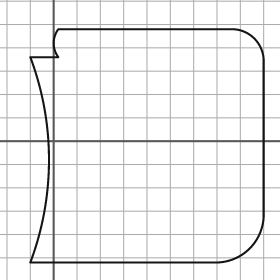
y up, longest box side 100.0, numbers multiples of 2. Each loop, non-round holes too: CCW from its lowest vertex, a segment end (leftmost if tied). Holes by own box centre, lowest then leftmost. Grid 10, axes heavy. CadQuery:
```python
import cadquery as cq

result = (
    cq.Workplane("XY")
    .moveTo(-10.0, -52.0)
    .lineTo(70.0, -52.0)
    .threePointArc((84.0, -46.0), (90.0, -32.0))
    .lineTo(90.0, 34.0)
    .threePointArc((86.0, 44.0), (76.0, 48.0))
    .lineTo(2.0, 48.0)
    .threePointArc((0.0, 42.0), (2.0, 36.0))
    .lineTo(-10.0, 36.0)
    .threePointArc((-2.0, -8.0), (-10.0, -52.0))
    .close()
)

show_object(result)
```